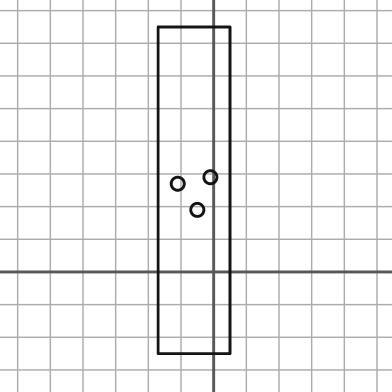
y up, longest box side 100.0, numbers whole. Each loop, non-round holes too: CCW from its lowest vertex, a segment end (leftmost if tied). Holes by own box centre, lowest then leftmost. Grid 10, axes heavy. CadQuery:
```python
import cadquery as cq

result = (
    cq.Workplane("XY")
    .moveTo(-17.0, -25.0)
    .lineTo(5.0, -25.0)
    .lineTo(5.0, 75.0)
    .lineTo(-17.0, 75.0)
    .close()
    .moveTo(-5.0, 19.0)
    .circle(2.0)
    .moveTo(-11.0, 27.0)
    .circle(2.0)
    .moveTo(-1.0, 29.0)
    .circle(2.0)
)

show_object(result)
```